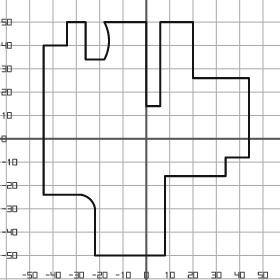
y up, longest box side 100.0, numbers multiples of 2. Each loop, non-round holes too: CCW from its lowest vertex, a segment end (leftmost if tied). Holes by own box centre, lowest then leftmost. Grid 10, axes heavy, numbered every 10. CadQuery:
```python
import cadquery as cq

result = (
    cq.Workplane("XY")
    .moveTo(-22.0, -50.0)
    .lineTo(8.0, -50.0)
    .lineTo(8.0, -16.0)
    .lineTo(34.0, -16.0)
    .lineTo(34.0, -8.0)
    .lineTo(44.0, -8.0)
    .lineTo(44.0, 26.0)
    .lineTo(20.0, 26.0)
    .lineTo(20.0, 50.0)
    .lineTo(6.0, 50.0)
    .lineTo(6.0, 14.0)
    .lineTo(0.0, 14.0)
    .lineTo(0.0, 50.0)
    .lineTo(-18.0, 50.0)
    .threePointArc((-16.0, 42.0), (-18.0, 34.0))
    .lineTo(-26.0, 34.0)
    .lineTo(-26.0, 50.0)
    .lineTo(-34.0, 50.0)
    .lineTo(-34.0, 40.0)
    .lineTo(-44.0, 40.0)
    .lineTo(-44.0, -24.0)
    .lineTo(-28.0, -24.0)
    .threePointArc((-24.0, -26.0), (-22.0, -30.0))
    .close()
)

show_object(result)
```